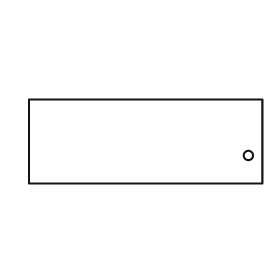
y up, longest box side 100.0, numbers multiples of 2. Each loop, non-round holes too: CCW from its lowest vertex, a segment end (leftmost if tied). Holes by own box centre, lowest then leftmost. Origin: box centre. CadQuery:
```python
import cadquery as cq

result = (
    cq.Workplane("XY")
    .moveTo(-50.0, -18.0)
    .lineTo(50.0, -18.0)
    .lineTo(50.0, 18.0)
    .lineTo(-50.0, 18.0)
    .close()
    .moveTo(44.0, -6.0)
    .circle(2.0)
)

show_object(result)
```